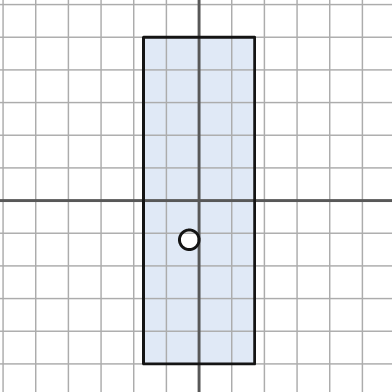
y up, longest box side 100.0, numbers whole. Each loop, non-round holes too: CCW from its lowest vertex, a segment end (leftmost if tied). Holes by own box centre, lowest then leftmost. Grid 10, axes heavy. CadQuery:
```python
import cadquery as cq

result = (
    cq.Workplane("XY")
    .moveTo(-17.0, -50.0)
    .lineTo(17.0, -50.0)
    .lineTo(17.0, 50.0)
    .lineTo(-17.0, 50.0)
    .close()
    .moveTo(-3.0, -12.0)
    .circle(3.0)
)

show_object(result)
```